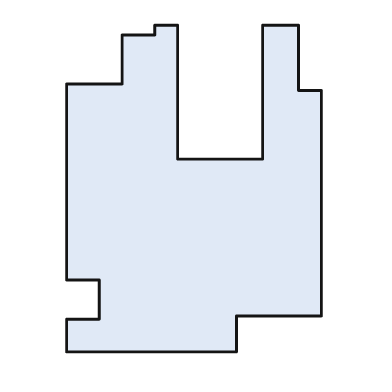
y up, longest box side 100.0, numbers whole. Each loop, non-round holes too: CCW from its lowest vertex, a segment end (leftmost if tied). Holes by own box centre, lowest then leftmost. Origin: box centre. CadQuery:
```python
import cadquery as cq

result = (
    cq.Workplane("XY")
    .moveTo(-39.0, -50.0)
    .lineTo(13.0, -50.0)
    .lineTo(13.0, -39.0)
    .lineTo(39.0, -39.0)
    .lineTo(39.0, 30.0)
    .lineTo(32.0, 30.0)
    .lineTo(32.0, 50.0)
    .lineTo(21.0, 50.0)
    .lineTo(21.0, 9.0)
    .lineTo(-5.0, 9.0)
    .lineTo(-5.0, 50.0)
    .lineTo(-12.0, 50.0)
    .lineTo(-12.0, 47.0)
    .lineTo(-22.0, 47.0)
    .lineTo(-22.0, 32.0)
    .lineTo(-39.0, 32.0)
    .lineTo(-39.0, -28.0)
    .lineTo(-29.0, -28.0)
    .lineTo(-29.0, -40.0)
    .lineTo(-39.0, -40.0)
    .close()
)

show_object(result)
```